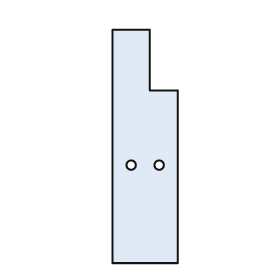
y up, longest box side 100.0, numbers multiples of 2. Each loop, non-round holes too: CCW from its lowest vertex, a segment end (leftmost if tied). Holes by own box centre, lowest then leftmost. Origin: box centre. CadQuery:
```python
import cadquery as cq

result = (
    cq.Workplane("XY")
    .moveTo(-14.0, -50.0)
    .lineTo(14.0, -50.0)
    .lineTo(14.0, 24.0)
    .lineTo(2.0, 24.0)
    .lineTo(2.0, 50.0)
    .lineTo(-14.0, 50.0)
    .close()
    .moveTo(-6.0, -8.0)
    .circle(2.0)
    .moveTo(6.0, -8.0)
    .circle(2.0)
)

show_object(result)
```